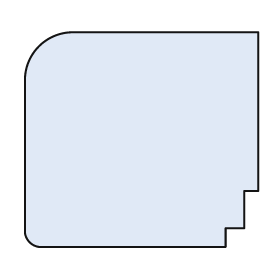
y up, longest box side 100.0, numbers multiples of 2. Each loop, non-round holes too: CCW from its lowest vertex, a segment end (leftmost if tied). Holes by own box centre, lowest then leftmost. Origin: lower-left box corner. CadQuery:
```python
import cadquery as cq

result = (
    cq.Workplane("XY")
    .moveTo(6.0, 0.0)
    .lineTo(86.0, 0.0)
    .lineTo(86.0, 8.0)
    .lineTo(94.0, 8.0)
    .lineTo(94.0, 24.0)
    .lineTo(100.0, 24.0)
    .lineTo(100.0, 92.0)
    .lineTo(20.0, 92.0)
    .threePointArc((6.0, 86.0), (0.0, 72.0))
    .lineTo(0.0, 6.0)
    .threePointArc((2.0, 2.0), (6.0, 0.0))
    .close()
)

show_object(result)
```